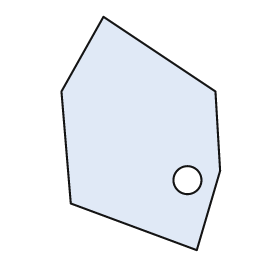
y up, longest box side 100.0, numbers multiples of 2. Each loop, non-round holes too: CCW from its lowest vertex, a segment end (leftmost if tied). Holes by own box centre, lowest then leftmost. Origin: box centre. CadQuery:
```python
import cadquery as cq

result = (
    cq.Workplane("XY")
    .moveTo(24.0, -50.0)
    .lineTo(34.0, -16.0)
    .lineTo(32.0, 18.0)
    .lineTo(-16.0, 50.0)
    .lineTo(-34.0, 18.0)
    .lineTo(-30.0, -30.0)
    .close()
    .moveTo(20.0, -20.0)
    .circle(6.0)
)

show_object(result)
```